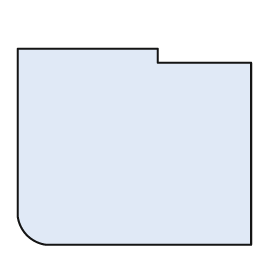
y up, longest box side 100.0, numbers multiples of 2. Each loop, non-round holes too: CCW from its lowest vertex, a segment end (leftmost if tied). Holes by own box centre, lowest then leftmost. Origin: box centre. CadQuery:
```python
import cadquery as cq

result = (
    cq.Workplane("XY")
    .moveTo(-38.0, -42.0)
    .lineTo(50.0, -42.0)
    .lineTo(50.0, 36.0)
    .lineTo(10.0, 36.0)
    .lineTo(10.0, 42.0)
    .lineTo(-50.0, 42.0)
    .lineTo(-50.0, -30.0)
    .threePointArc((-46.0, -38.0), (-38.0, -42.0))
    .close()
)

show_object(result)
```